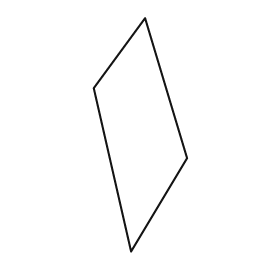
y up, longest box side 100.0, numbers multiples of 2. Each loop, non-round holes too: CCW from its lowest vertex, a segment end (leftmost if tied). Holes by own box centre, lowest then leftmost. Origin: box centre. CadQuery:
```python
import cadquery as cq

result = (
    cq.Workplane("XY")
    .moveTo(-4.0, -50.0)
    .lineTo(20.0, -10.0)
    .lineTo(2.0, 50.0)
    .lineTo(-20.0, 20.0)
    .close()
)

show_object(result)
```